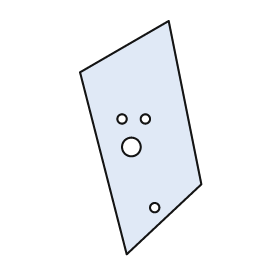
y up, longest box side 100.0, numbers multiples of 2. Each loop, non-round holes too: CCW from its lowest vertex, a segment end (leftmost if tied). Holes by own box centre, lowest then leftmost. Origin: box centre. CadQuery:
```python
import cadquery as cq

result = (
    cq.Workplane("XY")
    .moveTo(-6.0, -50.0)
    .lineTo(26.0, -20.0)
    .lineTo(12.0, 50.0)
    .lineTo(-26.0, 28.0)
    .close()
    .moveTo(6.0, -30.0)
    .circle(2.0)
    .moveTo(-4.0, -4.0)
    .circle(4.0)
    .moveTo(-8.0, 8.0)
    .circle(2.0)
    .moveTo(2.0, 8.0)
    .circle(2.0)
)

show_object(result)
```